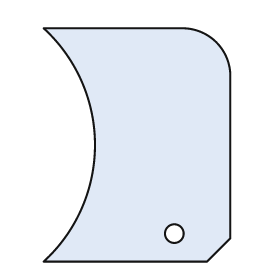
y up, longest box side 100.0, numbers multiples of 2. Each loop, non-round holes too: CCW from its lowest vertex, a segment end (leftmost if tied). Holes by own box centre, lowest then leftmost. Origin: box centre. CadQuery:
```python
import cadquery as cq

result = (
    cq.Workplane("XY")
    .moveTo(-40.0, -50.0)
    .lineTo(30.0, -50.0)
    .lineTo(40.0, -40.0)
    .lineTo(40.0, 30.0)
    .threePointArc((34.0, 44.0), (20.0, 50.0))
    .lineTo(-40.0, 50.0)
    .threePointArc((-18.0, 0.0), (-40.0, -50.0))
    .close()
    .moveTo(16.0, -38.0)
    .circle(4.0)
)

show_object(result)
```